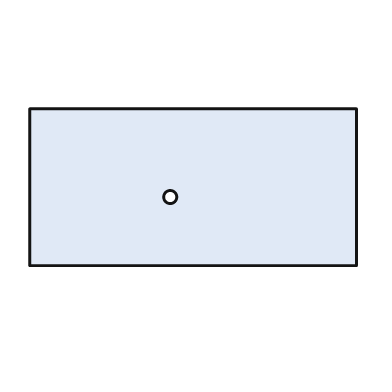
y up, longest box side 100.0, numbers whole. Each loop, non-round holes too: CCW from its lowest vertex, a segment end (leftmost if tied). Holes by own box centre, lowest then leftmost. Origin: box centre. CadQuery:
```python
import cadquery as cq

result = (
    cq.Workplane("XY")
    .moveTo(-50.0, -24.0)
    .lineTo(50.0, -24.0)
    .lineTo(50.0, 24.0)
    .lineTo(-50.0, 24.0)
    .close()
    .moveTo(-7.0, -3.0)
    .circle(2.0)
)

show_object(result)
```